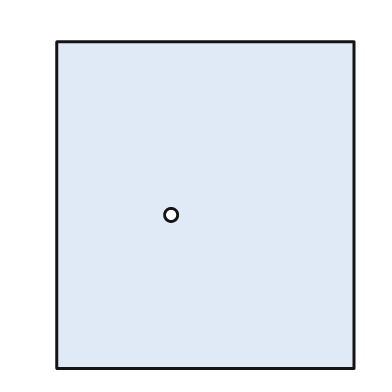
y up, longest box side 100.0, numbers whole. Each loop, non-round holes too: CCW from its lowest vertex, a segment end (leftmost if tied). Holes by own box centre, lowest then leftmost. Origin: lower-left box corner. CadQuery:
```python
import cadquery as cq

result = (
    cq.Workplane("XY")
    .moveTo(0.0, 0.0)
    .lineTo(91.0, 0.0)
    .lineTo(91.0, 100.0)
    .lineTo(0.0, 100.0)
    .close()
    .moveTo(35.0, 47.0)
    .circle(2.0)
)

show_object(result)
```